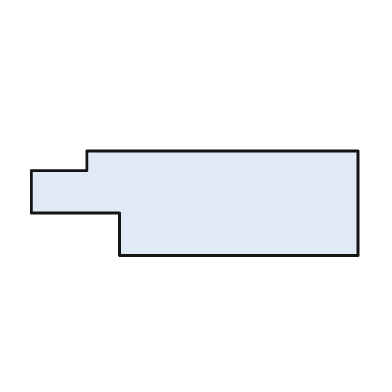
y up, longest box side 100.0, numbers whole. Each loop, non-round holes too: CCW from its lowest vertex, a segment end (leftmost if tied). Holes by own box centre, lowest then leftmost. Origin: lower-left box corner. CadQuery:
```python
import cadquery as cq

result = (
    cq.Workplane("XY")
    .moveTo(27.0, 0.0)
    .lineTo(100.0, 0.0)
    .lineTo(100.0, 32.0)
    .lineTo(17.0, 32.0)
    .lineTo(17.0, 26.0)
    .lineTo(0.0, 26.0)
    .lineTo(0.0, 13.0)
    .lineTo(27.0, 13.0)
    .close()
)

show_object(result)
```